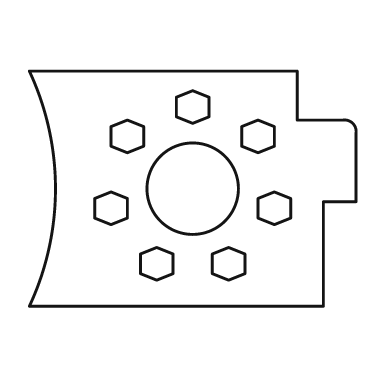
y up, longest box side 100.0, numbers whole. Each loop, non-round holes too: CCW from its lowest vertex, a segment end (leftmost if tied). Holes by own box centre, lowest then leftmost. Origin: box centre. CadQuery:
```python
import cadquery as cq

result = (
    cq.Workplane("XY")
    .moveTo(-50.0, -36.0)
    .lineTo(40.0, -36.0)
    .lineTo(40.0, -4.0)
    .lineTo(50.0, -4.0)
    .lineTo(50.0, 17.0)
    .threePointArc((49.0, 20.0), (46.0, 21.0))
    .lineTo(32.0, 21.0)
    .lineTo(32.0, 36.0)
    .lineTo(-50.0, 36.0)
    .threePointArc((-42.0, 0.0), (-50.0, -36.0))
    .close()
    .moveTo(-11.0, -28.0)
    .lineTo(-6.0, -26.0)
    .lineTo(-6.0, -20.0)
    .lineTo(-11.0, -18.0)
    .lineTo(-16.0, -20.0)
    .lineTo(-16.0, -26.0)
    .close()
    .moveTo(11.0, -28.0)
    .lineTo(16.0, -26.0)
    .lineTo(16.0, -20.0)
    .lineTo(11.0, -18.0)
    .lineTo(6.0, -20.0)
    .lineTo(6.0, -26.0)
    .close()
    .moveTo(-25.0, -11.0)
    .lineTo(-20.0, -9.0)
    .lineTo(-20.0, -3.0)
    .lineTo(-25.0, -1.0)
    .lineTo(-30.0, -3.0)
    .lineTo(-30.0, -9.0)
    .close()
    .moveTo(25.0, -11.0)
    .lineTo(30.0, -9.0)
    .lineTo(30.0, -3.0)
    .lineTo(25.0, -1.0)
    .lineTo(20.0, -3.0)
    .lineTo(20.0, -9.0)
    .close()
    .moveTo(0.0, 0.0)
    .circle(14.0)
    .moveTo(-20.0, 11.0)
    .lineTo(-15.0, 13.0)
    .lineTo(-15.0, 19.0)
    .lineTo(-20.0, 21.0)
    .lineTo(-25.0, 19.0)
    .lineTo(-25.0, 13.0)
    .close()
    .moveTo(20.0, 11.0)
    .lineTo(25.0, 13.0)
    .lineTo(25.0, 19.0)
    .lineTo(20.0, 21.0)
    .lineTo(15.0, 19.0)
    .lineTo(15.0, 13.0)
    .close()
    .moveTo(0.0, 20.0)
    .lineTo(5.0, 22.0)
    .lineTo(5.0, 28.0)
    .lineTo(0.0, 30.0)
    .lineTo(-5.0, 28.0)
    .lineTo(-5.0, 22.0)
    .close()
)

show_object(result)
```